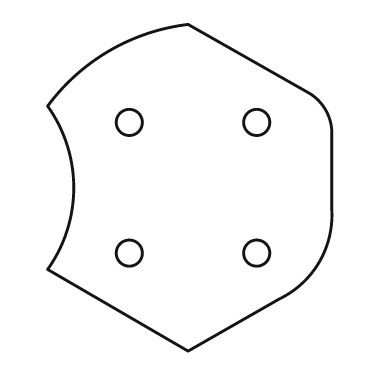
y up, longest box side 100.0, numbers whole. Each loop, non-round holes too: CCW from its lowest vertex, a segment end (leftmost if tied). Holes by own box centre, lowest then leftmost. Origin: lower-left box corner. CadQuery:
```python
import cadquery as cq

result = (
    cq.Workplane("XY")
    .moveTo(43.0, 0.0)
    .lineTo(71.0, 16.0)
    .threePointArc((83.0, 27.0), (87.0, 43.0))
    .lineTo(87.0, 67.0)
    .threePointArc((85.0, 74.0), (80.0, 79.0))
    .lineTo(43.0, 100.0)
    .threePointArc((19.0, 92.0), (0.0, 75.0))
    .threePointArc((8.0, 50.0), (0.0, 25.0))
    .close()
    .moveTo(25.0, 30.0)
    .circle(4.0)
    .moveTo(64.0, 30.0)
    .circle(4.0)
    .moveTo(25.0, 70.0)
    .circle(4.0)
    .moveTo(64.0, 70.0)
    .circle(4.0)
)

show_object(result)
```